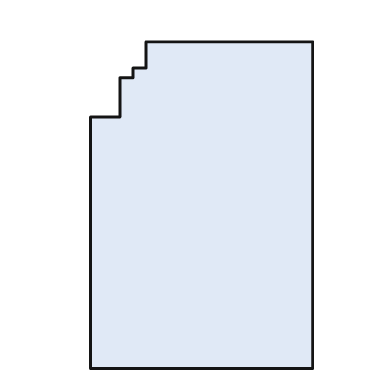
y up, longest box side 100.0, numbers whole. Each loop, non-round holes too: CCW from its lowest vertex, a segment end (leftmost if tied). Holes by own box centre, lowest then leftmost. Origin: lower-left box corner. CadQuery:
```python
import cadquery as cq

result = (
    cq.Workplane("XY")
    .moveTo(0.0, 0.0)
    .lineTo(68.0, 0.0)
    .lineTo(68.0, 100.0)
    .lineTo(17.0, 100.0)
    .lineTo(17.0, 92.0)
    .lineTo(13.0, 92.0)
    .lineTo(13.0, 89.0)
    .lineTo(9.0, 89.0)
    .lineTo(9.0, 77.0)
    .lineTo(0.0, 77.0)
    .close()
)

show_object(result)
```